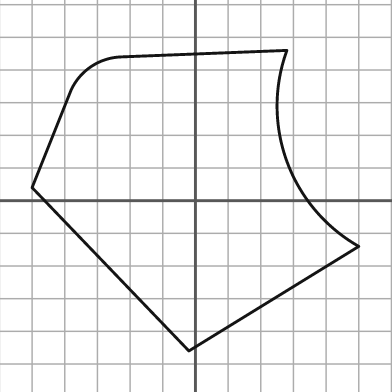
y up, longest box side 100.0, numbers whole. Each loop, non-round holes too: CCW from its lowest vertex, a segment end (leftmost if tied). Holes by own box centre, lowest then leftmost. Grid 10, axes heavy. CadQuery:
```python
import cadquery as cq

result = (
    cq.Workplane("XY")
    .moveTo(-2.0, -46.0)
    .lineTo(50.0, -14.0)
    .threePointArc((28.0, 12.0), (28.0, 46.0))
    .lineTo(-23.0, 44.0)
    .threePointArc((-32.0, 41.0), (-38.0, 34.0))
    .lineTo(-50.0, 4.0)
    .close()
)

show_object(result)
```